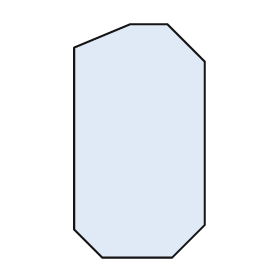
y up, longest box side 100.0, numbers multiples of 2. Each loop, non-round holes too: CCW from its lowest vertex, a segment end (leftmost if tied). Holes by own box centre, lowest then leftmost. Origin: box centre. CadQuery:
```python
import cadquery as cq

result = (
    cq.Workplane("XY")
    .moveTo(-16.0, -50.0)
    .lineTo(14.0, -50.0)
    .lineTo(28.0, -36.0)
    .lineTo(28.0, 34.0)
    .lineTo(12.0, 50.0)
    .lineTo(-4.0, 50.0)
    .lineTo(-28.0, 40.0)
    .lineTo(-28.0, -38.0)
    .close()
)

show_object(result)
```